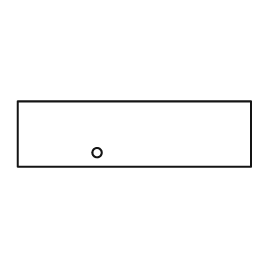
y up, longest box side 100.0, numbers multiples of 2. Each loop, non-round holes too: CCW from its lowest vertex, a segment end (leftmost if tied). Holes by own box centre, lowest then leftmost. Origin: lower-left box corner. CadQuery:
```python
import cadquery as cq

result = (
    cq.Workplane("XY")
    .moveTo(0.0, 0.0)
    .lineTo(100.0, 0.0)
    .lineTo(100.0, 28.0)
    .lineTo(0.0, 28.0)
    .close()
    .moveTo(34.0, 6.0)
    .circle(2.0)
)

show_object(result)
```